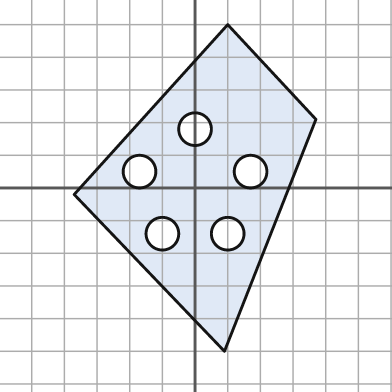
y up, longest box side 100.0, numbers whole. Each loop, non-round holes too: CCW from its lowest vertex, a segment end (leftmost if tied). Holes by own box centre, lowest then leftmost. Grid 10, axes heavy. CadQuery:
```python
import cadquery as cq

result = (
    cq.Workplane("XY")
    .moveTo(9.0, -50.0)
    .lineTo(37.0, 21.0)
    .lineTo(10.0, 50.0)
    .lineTo(-37.0, -2.0)
    .close()
    .moveTo(-10.0, -14.0)
    .circle(5.0)
    .moveTo(10.0, -14.0)
    .circle(5.0)
    .moveTo(-17.0, 5.0)
    .circle(5.0)
    .moveTo(17.0, 5.0)
    .circle(5.0)
    .moveTo(0.0, 18.0)
    .circle(5.0)
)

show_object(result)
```